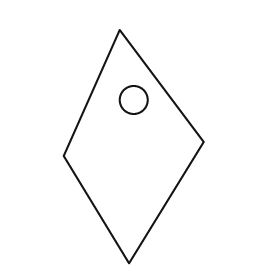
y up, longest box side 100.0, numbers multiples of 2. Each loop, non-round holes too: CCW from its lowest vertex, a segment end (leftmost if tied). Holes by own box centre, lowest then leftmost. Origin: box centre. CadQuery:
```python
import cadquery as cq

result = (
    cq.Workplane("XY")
    .moveTo(-2.0, -50.0)
    .lineTo(30.0, 2.0)
    .lineTo(-6.0, 50.0)
    .lineTo(-30.0, -4.0)
    .close()
    .moveTo(0.0, 20.0)
    .circle(6.0)
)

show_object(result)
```